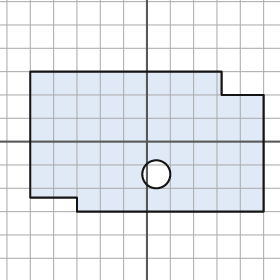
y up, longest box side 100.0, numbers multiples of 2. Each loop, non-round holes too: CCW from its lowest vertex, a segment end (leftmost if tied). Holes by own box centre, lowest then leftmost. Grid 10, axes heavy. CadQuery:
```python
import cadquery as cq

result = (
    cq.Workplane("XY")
    .moveTo(-30.0, -30.0)
    .lineTo(50.0, -30.0)
    .lineTo(50.0, 20.0)
    .lineTo(32.0, 20.0)
    .lineTo(32.0, 30.0)
    .lineTo(-50.0, 30.0)
    .lineTo(-50.0, -24.0)
    .lineTo(-30.0, -24.0)
    .close()
    .moveTo(4.0, -14.0)
    .circle(6.0)
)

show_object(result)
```